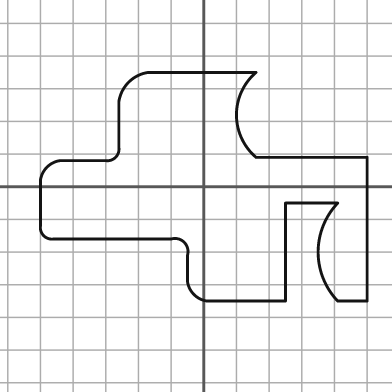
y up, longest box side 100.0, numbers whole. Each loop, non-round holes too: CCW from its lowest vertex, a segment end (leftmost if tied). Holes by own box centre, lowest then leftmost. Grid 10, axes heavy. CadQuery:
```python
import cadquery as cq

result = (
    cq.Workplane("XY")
    .moveTo(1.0, -35.0)
    .lineTo(25.0, -35.0)
    .lineTo(25.0, -5.0)
    .lineTo(41.0, -5.0)
    .threePointArc((35.0, -20.0), (41.0, -35.0))
    .lineTo(50.0, -35.0)
    .lineTo(50.0, 9.0)
    .lineTo(16.0, 9.0)
    .threePointArc((10.0, 22.0), (16.0, 35.0))
    .lineTo(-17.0, 35.0)
    .threePointArc((-23.0, 32.0), (-26.0, 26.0))
    .lineTo(-26.0, 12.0)
    .threePointArc((-27.0, 9.0), (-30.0, 8.0))
    .lineTo(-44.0, 8.0)
    .threePointArc((-48.0, 6.0), (-50.0, 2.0))
    .lineTo(-50.0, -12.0)
    .threePointArc((-49.0, -15.0), (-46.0, -16.0))
    .lineTo(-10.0, -16.0)
    .threePointArc((-6.0, -17.0), (-5.0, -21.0))
    .lineTo(-5.0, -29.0)
    .threePointArc((-3.0, -33.0), (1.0, -35.0))
    .close()
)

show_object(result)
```